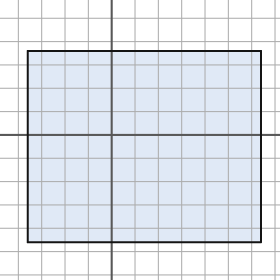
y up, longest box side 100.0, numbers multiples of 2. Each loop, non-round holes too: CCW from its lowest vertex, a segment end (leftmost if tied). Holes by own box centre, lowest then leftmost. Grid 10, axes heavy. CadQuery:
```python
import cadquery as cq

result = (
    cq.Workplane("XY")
    .moveTo(-36.0, -46.0)
    .lineTo(64.0, -46.0)
    .lineTo(64.0, 36.0)
    .lineTo(-36.0, 36.0)
    .close()
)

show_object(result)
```